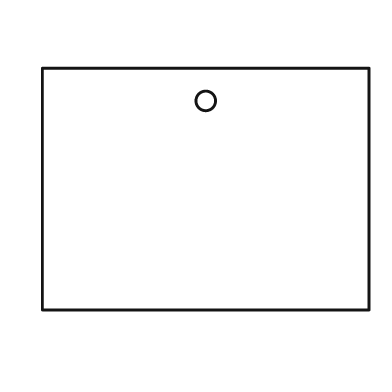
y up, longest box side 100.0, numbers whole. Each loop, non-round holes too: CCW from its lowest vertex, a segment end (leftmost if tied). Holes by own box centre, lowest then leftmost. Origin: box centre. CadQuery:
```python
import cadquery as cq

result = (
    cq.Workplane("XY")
    .moveTo(-50.0, -37.0)
    .lineTo(50.0, -37.0)
    .lineTo(50.0, 37.0)
    .lineTo(-50.0, 37.0)
    .close()
    .moveTo(0.0, 27.0)
    .circle(3.0)
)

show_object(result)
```